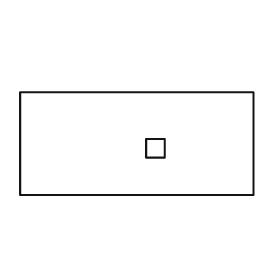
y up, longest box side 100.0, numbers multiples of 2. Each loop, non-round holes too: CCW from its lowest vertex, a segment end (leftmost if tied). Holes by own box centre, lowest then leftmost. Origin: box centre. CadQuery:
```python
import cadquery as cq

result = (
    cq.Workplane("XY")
    .moveTo(-50.0, -22.0)
    .lineTo(50.0, -22.0)
    .lineTo(50.0, 22.0)
    .lineTo(-50.0, 22.0)
    .close()
    .moveTo(4.0, -6.0)
    .lineTo(12.0, -6.0)
    .lineTo(12.0, 2.0)
    .lineTo(4.0, 2.0)
    .close()
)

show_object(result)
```